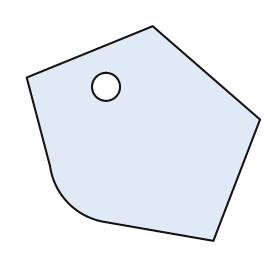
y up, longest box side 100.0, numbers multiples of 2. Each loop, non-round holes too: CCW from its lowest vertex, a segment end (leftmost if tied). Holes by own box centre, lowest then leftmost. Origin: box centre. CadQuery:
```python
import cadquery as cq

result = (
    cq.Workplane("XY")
    .moveTo(30.0, -46.0)
    .lineTo(50.0, 6.0)
    .lineTo(4.0, 46.0)
    .lineTo(-50.0, 24.0)
    .lineTo(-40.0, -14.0)
    .threePointArc((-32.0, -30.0), (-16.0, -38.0))
    .close()
    .moveTo(-16.0, 20.0)
    .circle(6.0)
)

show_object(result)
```